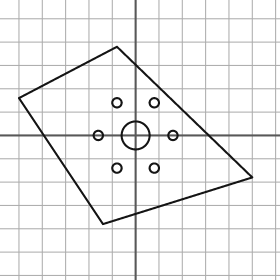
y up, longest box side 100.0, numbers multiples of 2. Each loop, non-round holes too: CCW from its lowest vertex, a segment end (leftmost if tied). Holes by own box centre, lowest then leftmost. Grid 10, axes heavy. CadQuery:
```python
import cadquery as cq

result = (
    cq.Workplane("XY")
    .moveTo(-14.0, -38.0)
    .lineTo(50.0, -18.0)
    .lineTo(-8.0, 38.0)
    .lineTo(-50.0, 16.0)
    .close()
    .moveTo(-8.0, -14.0)
    .circle(2.0)
    .moveTo(8.0, -14.0)
    .circle(2.0)
    .moveTo(-16.0, 0.0)
    .circle(2.0)
    .moveTo(0.0, 0.0)
    .circle(6.0)
    .moveTo(16.0, 0.0)
    .circle(2.0)
    .moveTo(-8.0, 14.0)
    .circle(2.0)
    .moveTo(8.0, 14.0)
    .circle(2.0)
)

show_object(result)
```